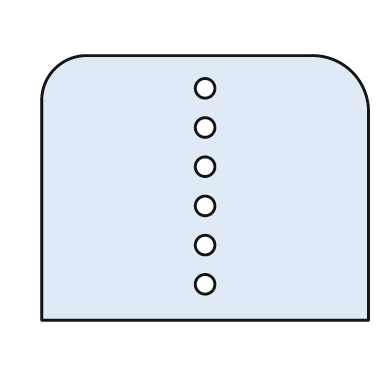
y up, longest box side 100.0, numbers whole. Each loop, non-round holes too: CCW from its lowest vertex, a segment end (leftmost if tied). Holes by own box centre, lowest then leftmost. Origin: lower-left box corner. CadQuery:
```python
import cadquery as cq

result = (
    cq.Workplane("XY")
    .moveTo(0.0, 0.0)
    .lineTo(100.0, 0.0)
    .lineTo(100.0, 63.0)
    .threePointArc((95.0, 76.0), (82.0, 81.0))
    .lineTo(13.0, 81.0)
    .threePointArc((4.0, 77.0), (0.0, 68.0))
    .close()
    .moveTo(50.0, 11.0)
    .circle(3.0)
    .moveTo(50.0, 23.0)
    .circle(3.0)
    .moveTo(50.0, 35.0)
    .circle(3.0)
    .moveTo(50.0, 47.0)
    .circle(3.0)
    .moveTo(50.0, 59.0)
    .circle(3.0)
    .moveTo(50.0, 71.0)
    .circle(3.0)
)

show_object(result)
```